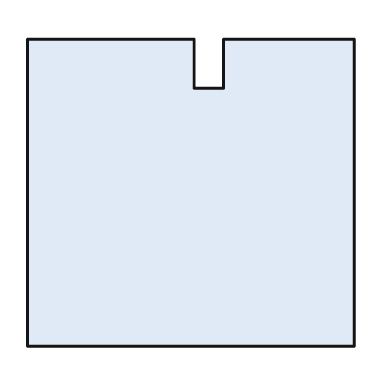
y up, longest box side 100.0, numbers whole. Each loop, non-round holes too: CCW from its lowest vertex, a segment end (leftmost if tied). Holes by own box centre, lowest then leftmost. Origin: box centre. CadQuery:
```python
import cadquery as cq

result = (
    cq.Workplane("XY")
    .moveTo(-50.0, -47.0)
    .lineTo(50.0, -47.0)
    .lineTo(50.0, 47.0)
    .lineTo(10.0, 47.0)
    .lineTo(10.0, 32.0)
    .lineTo(1.0, 32.0)
    .lineTo(1.0, 47.0)
    .lineTo(-50.0, 47.0)
    .close()
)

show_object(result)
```